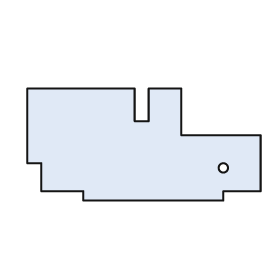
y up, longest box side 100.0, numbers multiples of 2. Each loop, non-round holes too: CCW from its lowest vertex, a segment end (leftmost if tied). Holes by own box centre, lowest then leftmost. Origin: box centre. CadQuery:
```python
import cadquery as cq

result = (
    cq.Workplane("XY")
    .moveTo(-26.0, -24.0)
    .lineTo(34.0, -24.0)
    .lineTo(34.0, -20.0)
    .lineTo(50.0, -20.0)
    .lineTo(50.0, 4.0)
    .lineTo(16.0, 4.0)
    .lineTo(16.0, 24.0)
    .lineTo(2.0, 24.0)
    .lineTo(2.0, 10.0)
    .lineTo(-4.0, 10.0)
    .lineTo(-4.0, 24.0)
    .lineTo(-50.0, 24.0)
    .lineTo(-50.0, -8.0)
    .lineTo(-44.0, -8.0)
    .lineTo(-44.0, -20.0)
    .lineTo(-26.0, -20.0)
    .close()
    .moveTo(34.0, -10.0)
    .circle(2.0)
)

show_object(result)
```